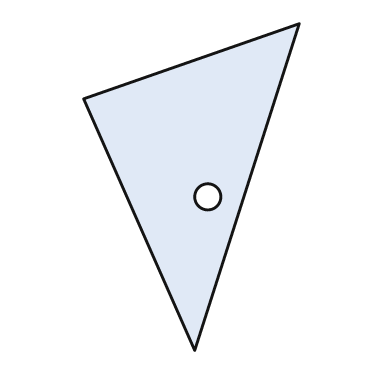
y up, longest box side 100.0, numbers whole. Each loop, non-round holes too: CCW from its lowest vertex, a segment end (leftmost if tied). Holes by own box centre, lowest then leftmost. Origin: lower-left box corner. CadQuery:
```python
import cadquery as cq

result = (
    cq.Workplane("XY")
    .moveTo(34.0, 0.0)
    .lineTo(66.0, 100.0)
    .lineTo(0.0, 77.0)
    .close()
    .moveTo(38.0, 47.0)
    .circle(4.0)
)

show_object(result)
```